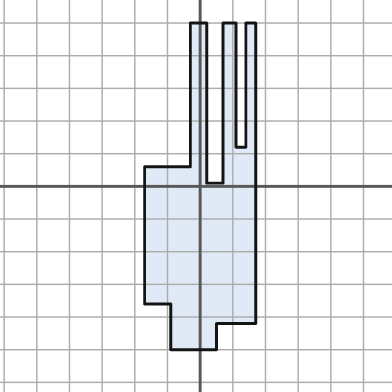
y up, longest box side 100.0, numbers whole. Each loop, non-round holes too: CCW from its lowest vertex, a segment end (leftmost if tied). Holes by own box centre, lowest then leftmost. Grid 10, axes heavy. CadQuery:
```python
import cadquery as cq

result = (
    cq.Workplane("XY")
    .moveTo(-9.0, -50.0)
    .lineTo(5.0, -50.0)
    .lineTo(5.0, -42.0)
    .lineTo(17.0, -42.0)
    .lineTo(17.0, 50.0)
    .lineTo(14.0, 50.0)
    .lineTo(14.0, 12.0)
    .lineTo(11.0, 12.0)
    .lineTo(11.0, 50.0)
    .lineTo(7.0, 50.0)
    .lineTo(7.0, 1.0)
    .lineTo(2.0, 1.0)
    .lineTo(2.0, 50.0)
    .lineTo(-3.0, 50.0)
    .lineTo(-3.0, 6.0)
    .lineTo(-17.0, 6.0)
    .lineTo(-17.0, -36.0)
    .lineTo(-9.0, -36.0)
    .close()
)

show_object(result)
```